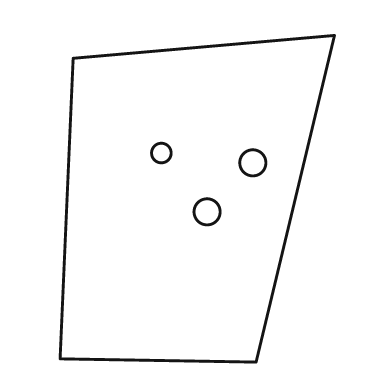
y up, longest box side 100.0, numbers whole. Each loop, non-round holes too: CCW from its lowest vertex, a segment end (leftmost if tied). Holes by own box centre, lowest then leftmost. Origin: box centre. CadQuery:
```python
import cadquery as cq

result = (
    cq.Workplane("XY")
    .moveTo(18.0, -50.0)
    .lineTo(42.0, 50.0)
    .lineTo(-38.0, 43.0)
    .lineTo(-42.0, -49.0)
    .close()
    .moveTo(3.0, -4.0)
    .circle(4.0)
    .moveTo(17.0, 11.0)
    .circle(4.0)
    .moveTo(-11.0, 14.0)
    .circle(3.0)
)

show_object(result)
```